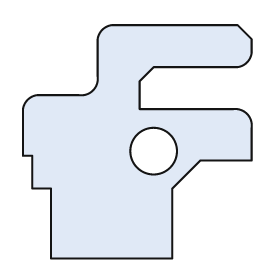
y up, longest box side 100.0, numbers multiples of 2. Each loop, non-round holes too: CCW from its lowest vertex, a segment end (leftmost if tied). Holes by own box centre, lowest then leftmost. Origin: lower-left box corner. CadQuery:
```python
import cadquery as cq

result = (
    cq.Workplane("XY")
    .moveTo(12.0, 0.0)
    .lineTo(64.0, 0.0)
    .lineTo(64.0, 30.0)
    .lineTo(76.0, 42.0)
    .lineTo(98.0, 42.0)
    .lineTo(98.0, 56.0)
    .threePointArc((96.0, 62.0), (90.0, 64.0))
    .lineTo(50.0, 64.0)
    .lineTo(50.0, 76.0)
    .lineTo(56.0, 82.0)
    .lineTo(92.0, 82.0)
    .threePointArc((96.0, 84.0), (98.0, 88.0))
    .lineTo(98.0, 94.0)
    .lineTo(92.0, 100.0)
    .lineTo(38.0, 100.0)
    .threePointArc((34.0, 98.0), (32.0, 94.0))
    .lineTo(32.0, 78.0)
    .threePointArc((30.0, 72.0), (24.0, 70.0))
    .lineTo(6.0, 70.0)
    .threePointArc((2.0, 68.0), (0.0, 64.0))
    .lineTo(0.0, 44.0)
    .lineTo(4.0, 44.0)
    .lineTo(4.0, 30.0)
    .lineTo(12.0, 30.0)
    .close()
    .moveTo(56.0, 46.0)
    .circle(10.0)
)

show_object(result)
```